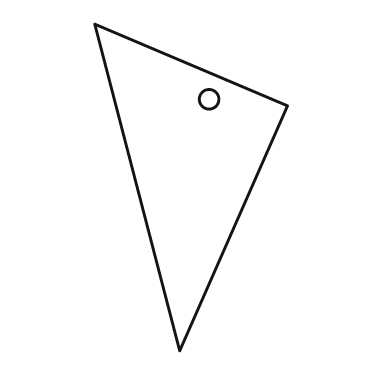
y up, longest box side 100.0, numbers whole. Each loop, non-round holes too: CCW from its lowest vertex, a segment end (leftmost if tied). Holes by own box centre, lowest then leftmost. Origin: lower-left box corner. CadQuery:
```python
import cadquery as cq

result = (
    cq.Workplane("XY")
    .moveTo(26.0, 0.0)
    .lineTo(59.0, 75.0)
    .lineTo(0.0, 100.0)
    .close()
    .moveTo(35.0, 77.0)
    .circle(3.0)
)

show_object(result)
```